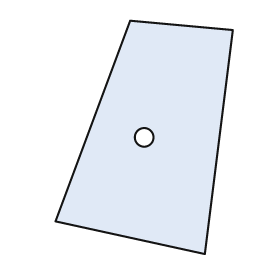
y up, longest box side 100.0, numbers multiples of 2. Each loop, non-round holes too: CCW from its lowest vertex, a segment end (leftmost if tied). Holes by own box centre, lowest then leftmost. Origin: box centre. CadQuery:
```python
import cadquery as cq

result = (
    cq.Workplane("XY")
    .moveTo(26.0, -50.0)
    .lineTo(38.0, 46.0)
    .lineTo(-6.0, 50.0)
    .lineTo(-38.0, -36.0)
    .close()
    .moveTo(0.0, 0.0)
    .circle(4.0)
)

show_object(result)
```